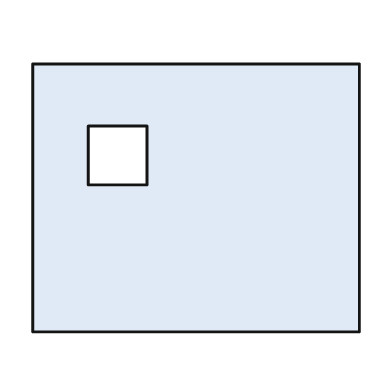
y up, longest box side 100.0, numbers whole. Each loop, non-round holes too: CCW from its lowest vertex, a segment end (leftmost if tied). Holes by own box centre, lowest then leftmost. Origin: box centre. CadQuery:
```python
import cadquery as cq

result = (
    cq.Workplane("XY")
    .moveTo(-50.0, -41.0)
    .lineTo(50.0, -41.0)
    .lineTo(50.0, 41.0)
    .lineTo(-50.0, 41.0)
    .close()
    .moveTo(-33.0, 4.0)
    .lineTo(-15.0, 4.0)
    .lineTo(-15.0, 22.0)
    .lineTo(-33.0, 22.0)
    .close()
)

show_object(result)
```